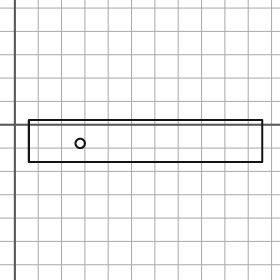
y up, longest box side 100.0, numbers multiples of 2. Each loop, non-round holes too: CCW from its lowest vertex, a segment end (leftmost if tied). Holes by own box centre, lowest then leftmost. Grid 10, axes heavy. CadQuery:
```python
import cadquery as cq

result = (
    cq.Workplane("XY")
    .moveTo(6.0, -16.0)
    .lineTo(106.0, -16.0)
    .lineTo(106.0, 2.0)
    .lineTo(6.0, 2.0)
    .close()
    .moveTo(28.0, -8.0)
    .circle(2.0)
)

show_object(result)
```